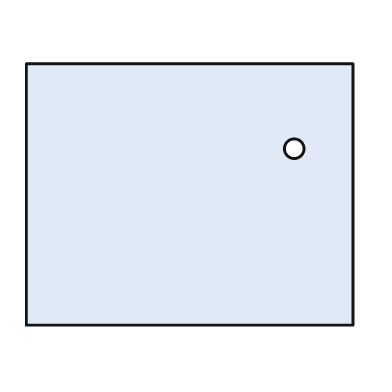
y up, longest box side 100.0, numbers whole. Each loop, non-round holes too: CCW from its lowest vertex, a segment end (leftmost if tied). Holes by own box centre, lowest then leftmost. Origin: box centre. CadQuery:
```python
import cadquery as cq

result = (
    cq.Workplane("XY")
    .moveTo(-50.0, -40.0)
    .lineTo(50.0, -40.0)
    .lineTo(50.0, 40.0)
    .lineTo(-50.0, 40.0)
    .close()
    .moveTo(32.0, 14.0)
    .circle(3.0)
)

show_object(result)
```